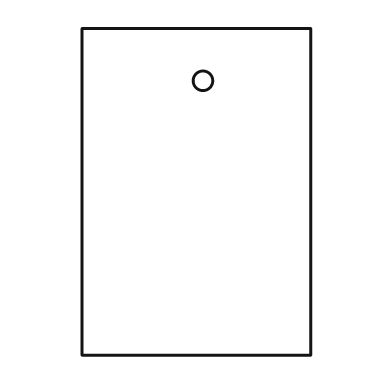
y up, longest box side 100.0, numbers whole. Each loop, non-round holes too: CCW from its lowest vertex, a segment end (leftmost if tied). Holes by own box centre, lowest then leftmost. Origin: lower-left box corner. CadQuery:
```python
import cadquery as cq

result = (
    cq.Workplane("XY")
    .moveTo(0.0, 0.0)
    .lineTo(70.0, 0.0)
    .lineTo(70.0, 100.0)
    .lineTo(0.0, 100.0)
    .close()
    .moveTo(37.0, 84.0)
    .circle(3.0)
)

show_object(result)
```